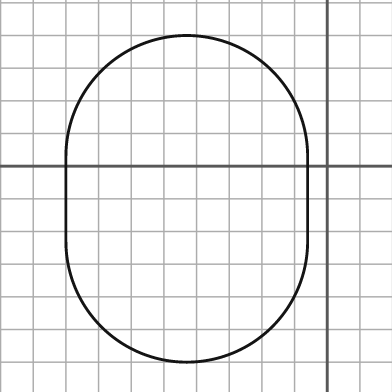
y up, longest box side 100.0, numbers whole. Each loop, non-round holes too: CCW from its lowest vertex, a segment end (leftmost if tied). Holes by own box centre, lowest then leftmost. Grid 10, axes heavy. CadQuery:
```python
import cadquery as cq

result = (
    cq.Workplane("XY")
    .moveTo(-80.0, -23.0)
    .threePointArc((-43.0, -60.0), (-6.0, -23.0))
    .lineTo(-6.0, 3.0)
    .threePointArc((-43.0, 40.0), (-80.0, 3.0))
    .close()
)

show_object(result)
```